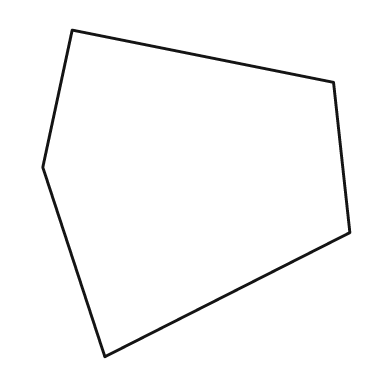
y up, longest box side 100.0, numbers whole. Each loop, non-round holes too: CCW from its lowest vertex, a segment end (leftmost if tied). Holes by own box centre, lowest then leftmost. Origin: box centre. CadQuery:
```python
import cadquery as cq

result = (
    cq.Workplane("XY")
    .moveTo(-28.0, -50.0)
    .lineTo(47.0, -12.0)
    .lineTo(42.0, 34.0)
    .lineTo(-38.0, 50.0)
    .lineTo(-47.0, 8.0)
    .close()
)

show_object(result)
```